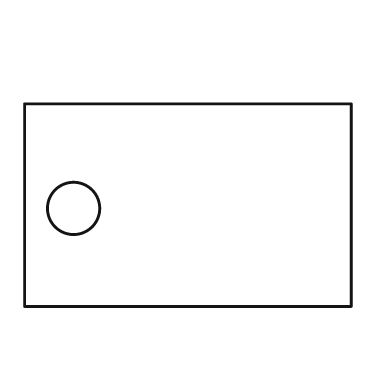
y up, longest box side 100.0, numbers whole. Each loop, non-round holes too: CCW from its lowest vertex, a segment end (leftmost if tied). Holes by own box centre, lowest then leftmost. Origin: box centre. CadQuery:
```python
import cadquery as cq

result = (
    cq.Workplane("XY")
    .moveTo(-50.0, -31.0)
    .lineTo(50.0, -31.0)
    .lineTo(50.0, 31.0)
    .lineTo(-50.0, 31.0)
    .close()
    .moveTo(-35.0, -1.0)
    .circle(8.0)
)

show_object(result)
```